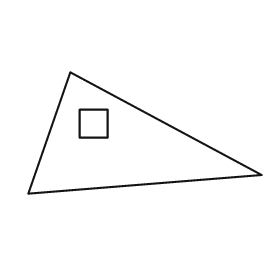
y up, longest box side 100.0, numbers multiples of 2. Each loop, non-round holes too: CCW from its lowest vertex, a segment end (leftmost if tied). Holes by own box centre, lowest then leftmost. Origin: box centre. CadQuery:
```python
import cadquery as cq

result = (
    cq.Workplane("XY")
    .moveTo(-50.0, -26.0)
    .lineTo(50.0, -18.0)
    .lineTo(-32.0, 26.0)
    .close()
    .moveTo(-28.0, -2.0)
    .lineTo(-16.0, -2.0)
    .lineTo(-16.0, 10.0)
    .lineTo(-28.0, 10.0)
    .close()
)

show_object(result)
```